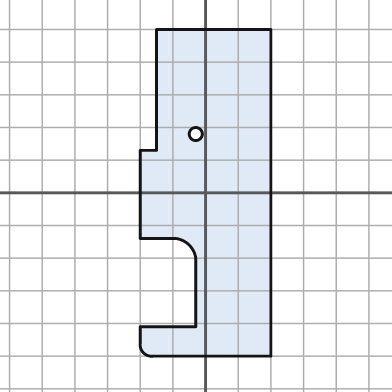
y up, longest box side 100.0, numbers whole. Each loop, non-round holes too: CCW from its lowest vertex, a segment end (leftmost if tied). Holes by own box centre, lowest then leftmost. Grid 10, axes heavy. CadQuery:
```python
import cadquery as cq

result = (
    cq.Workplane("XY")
    .moveTo(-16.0, -50.0)
    .lineTo(20.0, -50.0)
    .lineTo(20.0, 50.0)
    .lineTo(-15.0, 50.0)
    .lineTo(-15.0, 13.0)
    .lineTo(-20.0, 13.0)
    .lineTo(-20.0, -14.0)
    .lineTo(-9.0, -14.0)
    .threePointArc((-5.0, -16.0), (-3.0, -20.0))
    .lineTo(-3.0, -41.0)
    .lineTo(-20.0, -41.0)
    .lineTo(-20.0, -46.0)
    .threePointArc((-19.0, -49.0), (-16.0, -50.0))
    .close()
    .moveTo(-3.0, 18.0)
    .circle(2.0)
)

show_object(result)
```